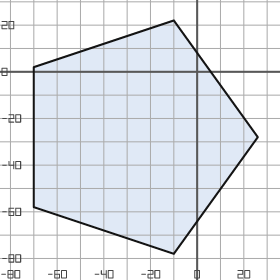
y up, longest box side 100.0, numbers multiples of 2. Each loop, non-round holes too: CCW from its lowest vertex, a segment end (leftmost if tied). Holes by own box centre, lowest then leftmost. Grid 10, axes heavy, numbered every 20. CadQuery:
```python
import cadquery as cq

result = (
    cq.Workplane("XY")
    .moveTo(-10.0, -78.0)
    .lineTo(26.0, -28.0)
    .lineTo(-10.0, 22.0)
    .lineTo(-70.0, 2.0)
    .lineTo(-70.0, -58.0)
    .close()
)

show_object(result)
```